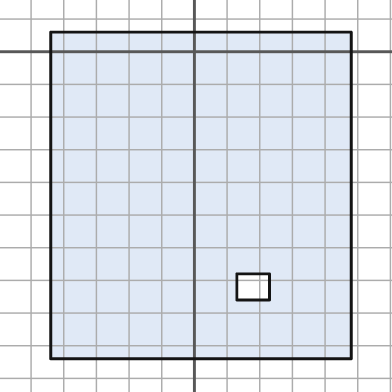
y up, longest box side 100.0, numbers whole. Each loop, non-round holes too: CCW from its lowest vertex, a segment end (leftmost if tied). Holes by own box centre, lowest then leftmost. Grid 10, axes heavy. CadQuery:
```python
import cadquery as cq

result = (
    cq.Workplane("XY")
    .moveTo(-44.0, -94.0)
    .lineTo(48.0, -94.0)
    .lineTo(48.0, 6.0)
    .lineTo(-44.0, 6.0)
    .close()
    .moveTo(13.0, -76.0)
    .lineTo(23.0, -76.0)
    .lineTo(23.0, -68.0)
    .lineTo(13.0, -68.0)
    .close()
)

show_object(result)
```